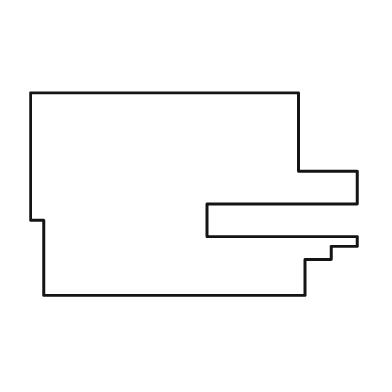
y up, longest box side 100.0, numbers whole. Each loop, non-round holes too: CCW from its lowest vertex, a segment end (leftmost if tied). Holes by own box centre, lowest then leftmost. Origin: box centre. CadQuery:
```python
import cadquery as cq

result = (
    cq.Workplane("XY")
    .moveTo(-46.0, -31.0)
    .lineTo(34.0, -31.0)
    .lineTo(34.0, -20.0)
    .lineTo(42.0, -20.0)
    .lineTo(42.0, -16.0)
    .lineTo(50.0, -16.0)
    .lineTo(50.0, -13.0)
    .lineTo(4.0, -13.0)
    .lineTo(4.0, -3.0)
    .lineTo(50.0, -3.0)
    .lineTo(50.0, 7.0)
    .lineTo(32.0, 7.0)
    .lineTo(32.0, 31.0)
    .lineTo(-50.0, 31.0)
    .lineTo(-50.0, -8.0)
    .lineTo(-46.0, -8.0)
    .close()
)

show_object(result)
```